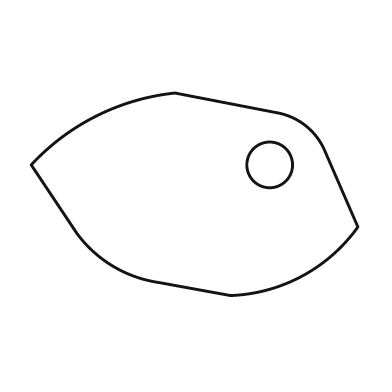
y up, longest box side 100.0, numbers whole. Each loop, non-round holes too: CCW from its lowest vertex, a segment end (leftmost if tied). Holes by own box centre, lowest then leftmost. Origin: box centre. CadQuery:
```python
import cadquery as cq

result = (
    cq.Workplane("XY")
    .moveTo(11.0, -31.0)
    .threePointArc((33.0, -25.0), (50.0, -10.0))
    .lineTo(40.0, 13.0)
    .threePointArc((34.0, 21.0), (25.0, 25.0))
    .lineTo(-6.0, 31.0)
    .threePointArc((-30.0, 24.0), (-50.0, 9.0))
    .lineTo(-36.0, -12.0)
    .threePointArc((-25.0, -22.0), (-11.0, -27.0))
    .close()
    .moveTo(23.0, 9.0)
    .circle(7.0)
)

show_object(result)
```